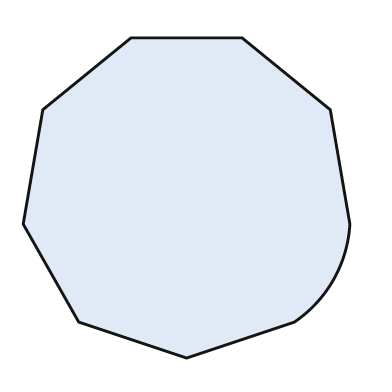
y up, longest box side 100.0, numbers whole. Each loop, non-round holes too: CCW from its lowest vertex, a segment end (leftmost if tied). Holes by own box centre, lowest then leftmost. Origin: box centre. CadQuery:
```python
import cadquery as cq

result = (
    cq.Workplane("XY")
    .moveTo(0.0, -49.0)
    .lineTo(33.0, -38.0)
    .threePointArc((45.0, -25.0), (50.0, -8.0))
    .lineTo(44.0, 27.0)
    .lineTo(17.0, 49.0)
    .lineTo(-17.0, 49.0)
    .lineTo(-44.0, 27.0)
    .lineTo(-50.0, -8.0)
    .lineTo(-33.0, -38.0)
    .close()
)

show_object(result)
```